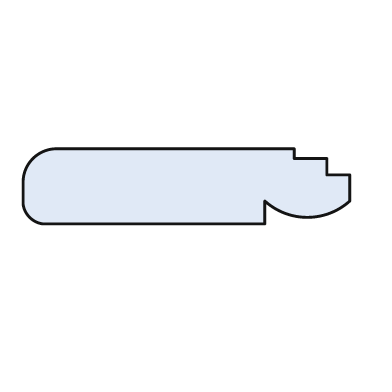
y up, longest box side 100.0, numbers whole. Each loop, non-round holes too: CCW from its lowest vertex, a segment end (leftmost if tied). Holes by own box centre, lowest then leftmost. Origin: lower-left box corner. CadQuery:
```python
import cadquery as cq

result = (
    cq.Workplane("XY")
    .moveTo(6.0, 0.0)
    .lineTo(74.0, 0.0)
    .lineTo(74.0, 7.0)
    .threePointArc((87.0, 2.0), (100.0, 7.0))
    .lineTo(100.0, 15.0)
    .lineTo(93.0, 15.0)
    .lineTo(93.0, 20.0)
    .lineTo(83.0, 20.0)
    .lineTo(83.0, 23.0)
    .lineTo(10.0, 23.0)
    .threePointArc((3.0, 20.0), (0.0, 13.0))
    .lineTo(0.0, 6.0)
    .threePointArc((2.0, 2.0), (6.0, 0.0))
    .close()
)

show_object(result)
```